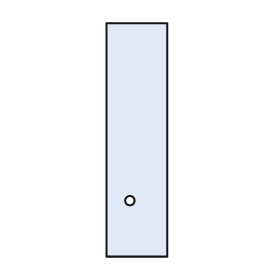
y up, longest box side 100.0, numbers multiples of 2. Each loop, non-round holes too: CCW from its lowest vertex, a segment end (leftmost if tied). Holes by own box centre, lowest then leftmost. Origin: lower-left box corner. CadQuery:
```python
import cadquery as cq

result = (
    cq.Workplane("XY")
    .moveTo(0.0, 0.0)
    .lineTo(26.0, 0.0)
    .lineTo(26.0, 100.0)
    .lineTo(0.0, 100.0)
    .close()
    .moveTo(10.0, 24.0)
    .circle(2.0)
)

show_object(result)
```